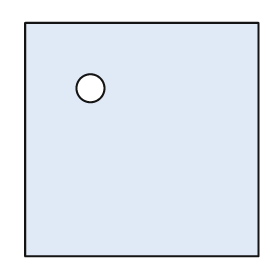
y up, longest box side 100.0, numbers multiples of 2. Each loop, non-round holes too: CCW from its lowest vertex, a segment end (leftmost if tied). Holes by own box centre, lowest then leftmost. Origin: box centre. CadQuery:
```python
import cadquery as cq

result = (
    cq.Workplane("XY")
    .moveTo(-50.0, -50.0)
    .lineTo(50.0, -50.0)
    .lineTo(50.0, 50.0)
    .lineTo(-50.0, 50.0)
    .close()
    .moveTo(-22.0, 22.0)
    .circle(6.0)
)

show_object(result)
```